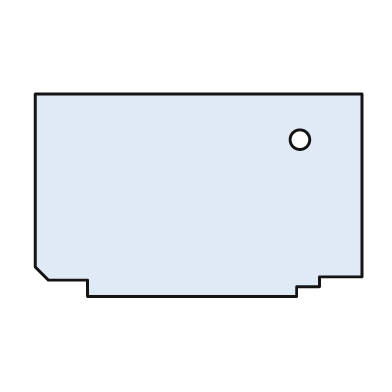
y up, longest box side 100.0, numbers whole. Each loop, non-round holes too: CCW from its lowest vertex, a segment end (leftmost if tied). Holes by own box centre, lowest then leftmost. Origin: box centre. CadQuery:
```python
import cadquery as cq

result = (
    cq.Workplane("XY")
    .moveTo(-34.0, -31.0)
    .lineTo(30.0, -31.0)
    .lineTo(30.0, -28.0)
    .lineTo(37.0, -28.0)
    .lineTo(37.0, -25.0)
    .lineTo(50.0, -25.0)
    .lineTo(50.0, 31.0)
    .lineTo(-50.0, 31.0)
    .lineTo(-50.0, -22.0)
    .lineTo(-46.0, -26.0)
    .lineTo(-34.0, -26.0)
    .close()
    .moveTo(31.0, 17.0)
    .circle(3.0)
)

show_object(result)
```